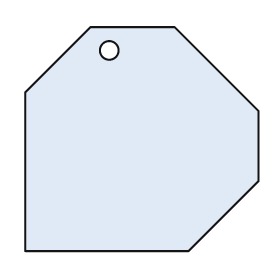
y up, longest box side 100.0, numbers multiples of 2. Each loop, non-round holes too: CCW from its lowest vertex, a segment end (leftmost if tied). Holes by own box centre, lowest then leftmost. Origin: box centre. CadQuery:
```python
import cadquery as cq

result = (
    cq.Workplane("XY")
    .moveTo(-50.0, -48.0)
    .lineTo(20.0, -48.0)
    .lineTo(50.0, -18.0)
    .lineTo(50.0, 12.0)
    .lineTo(14.0, 48.0)
    .lineTo(-22.0, 48.0)
    .lineTo(-50.0, 20.0)
    .close()
    .moveTo(-14.0, 38.0)
    .circle(4.0)
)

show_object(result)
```